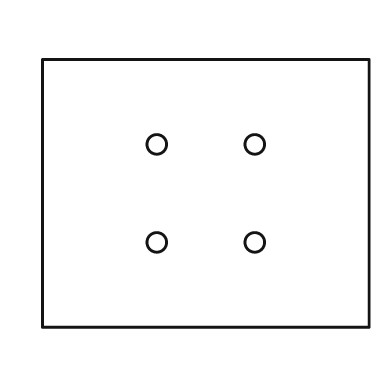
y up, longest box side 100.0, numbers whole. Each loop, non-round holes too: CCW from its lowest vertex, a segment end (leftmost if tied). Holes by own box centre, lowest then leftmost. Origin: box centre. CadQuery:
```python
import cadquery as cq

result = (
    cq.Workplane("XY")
    .moveTo(-50.0, -41.0)
    .lineTo(50.0, -41.0)
    .lineTo(50.0, 41.0)
    .lineTo(-50.0, 41.0)
    .close()
    .moveTo(-15.0, -15.0)
    .circle(3.0)
    .moveTo(15.0, -15.0)
    .circle(3.0)
    .moveTo(-15.0, 15.0)
    .circle(3.0)
    .moveTo(15.0, 15.0)
    .circle(3.0)
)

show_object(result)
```